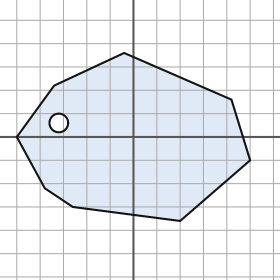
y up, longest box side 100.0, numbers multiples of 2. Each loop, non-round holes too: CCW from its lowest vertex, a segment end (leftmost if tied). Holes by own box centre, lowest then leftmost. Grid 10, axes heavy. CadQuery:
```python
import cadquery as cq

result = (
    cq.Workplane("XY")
    .moveTo(20.0, -36.0)
    .lineTo(50.0, -10.0)
    .lineTo(42.0, 16.0)
    .lineTo(-4.0, 36.0)
    .lineTo(-34.0, 22.0)
    .lineTo(-50.0, 0.0)
    .lineTo(-38.0, -22.0)
    .lineTo(-26.0, -30.0)
    .close()
    .moveTo(-32.0, 6.0)
    .circle(4.0)
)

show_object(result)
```